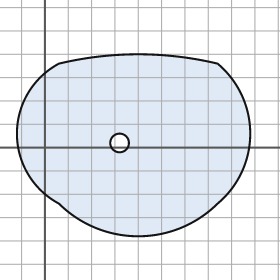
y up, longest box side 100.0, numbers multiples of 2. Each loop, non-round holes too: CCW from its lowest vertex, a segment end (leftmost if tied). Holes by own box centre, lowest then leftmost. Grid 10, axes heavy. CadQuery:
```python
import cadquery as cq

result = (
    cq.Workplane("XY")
    .moveTo(6.0, -24.0)
    .threePointArc((40.0, -38.0), (74.0, -24.0))
    .threePointArc((88.0, 6.0), (74.0, 36.0))
    .threePointArc((40.0, 40.0), (6.0, 36.0))
    .threePointArc((-12.0, 6.0), (6.0, -24.0))
    .close()
    .moveTo(32.0, 2.0)
    .circle(4.0)
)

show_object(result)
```